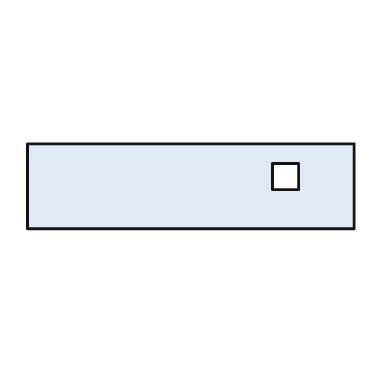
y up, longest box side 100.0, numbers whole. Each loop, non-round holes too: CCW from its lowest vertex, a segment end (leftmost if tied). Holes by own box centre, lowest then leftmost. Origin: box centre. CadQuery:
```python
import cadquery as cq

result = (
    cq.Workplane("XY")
    .moveTo(-50.0, -13.0)
    .lineTo(50.0, -13.0)
    .lineTo(50.0, 13.0)
    .lineTo(-50.0, 13.0)
    .close()
    .moveTo(25.0, -1.0)
    .lineTo(33.0, -1.0)
    .lineTo(33.0, 7.0)
    .lineTo(25.0, 7.0)
    .close()
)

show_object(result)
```